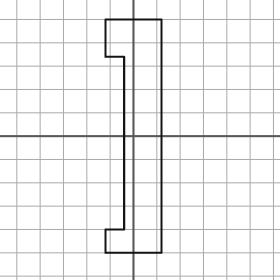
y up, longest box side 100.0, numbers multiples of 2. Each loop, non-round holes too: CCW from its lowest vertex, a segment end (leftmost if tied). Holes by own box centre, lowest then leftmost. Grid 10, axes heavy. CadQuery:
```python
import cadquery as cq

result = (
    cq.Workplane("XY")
    .moveTo(-12.0, -50.0)
    .lineTo(12.0, -50.0)
    .lineTo(12.0, 50.0)
    .lineTo(-12.0, 50.0)
    .lineTo(-12.0, 34.0)
    .lineTo(-4.0, 34.0)
    .lineTo(-4.0, -40.0)
    .lineTo(-12.0, -40.0)
    .close()
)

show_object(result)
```